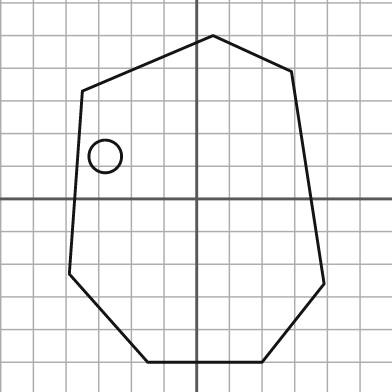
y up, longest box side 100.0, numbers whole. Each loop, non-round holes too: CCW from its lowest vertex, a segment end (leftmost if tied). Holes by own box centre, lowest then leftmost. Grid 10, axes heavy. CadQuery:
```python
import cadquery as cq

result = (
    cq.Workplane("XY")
    .moveTo(-15.0, -50.0)
    .lineTo(20.0, -50.0)
    .lineTo(39.0, -26.0)
    .lineTo(29.0, 39.0)
    .lineTo(5.0, 50.0)
    .lineTo(-35.0, 33.0)
    .lineTo(-39.0, -23.0)
    .close()
    .moveTo(-28.0, 13.0)
    .circle(5.0)
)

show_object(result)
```